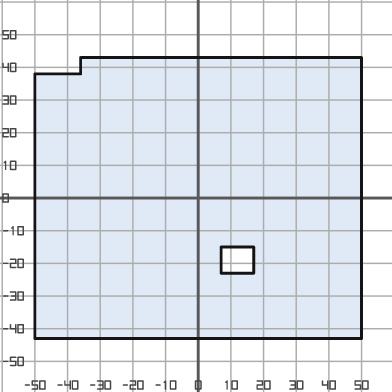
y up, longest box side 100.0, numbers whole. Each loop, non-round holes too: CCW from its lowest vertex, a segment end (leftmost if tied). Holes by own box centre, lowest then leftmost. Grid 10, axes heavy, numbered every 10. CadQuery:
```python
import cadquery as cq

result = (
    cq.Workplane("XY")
    .moveTo(-50.0, -43.0)
    .lineTo(50.0, -43.0)
    .lineTo(50.0, 43.0)
    .lineTo(-36.0, 43.0)
    .lineTo(-36.0, 38.0)
    .lineTo(-50.0, 38.0)
    .close()
    .moveTo(7.0, -23.0)
    .lineTo(17.0, -23.0)
    .lineTo(17.0, -15.0)
    .lineTo(7.0, -15.0)
    .close()
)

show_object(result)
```